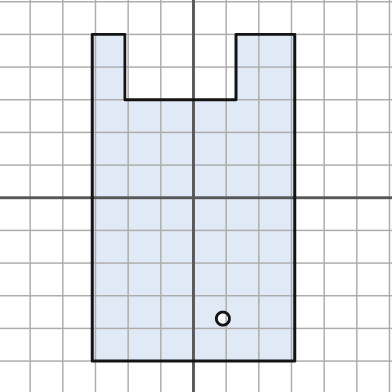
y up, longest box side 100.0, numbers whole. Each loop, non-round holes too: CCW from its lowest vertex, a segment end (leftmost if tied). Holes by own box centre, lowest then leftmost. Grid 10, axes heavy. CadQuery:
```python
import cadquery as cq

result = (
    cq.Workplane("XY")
    .moveTo(-31.0, -50.0)
    .lineTo(31.0, -50.0)
    .lineTo(31.0, 50.0)
    .lineTo(13.0, 50.0)
    .lineTo(13.0, 30.0)
    .lineTo(-21.0, 30.0)
    .lineTo(-21.0, 50.0)
    .lineTo(-31.0, 50.0)
    .close()
    .moveTo(9.0, -37.0)
    .circle(2.0)
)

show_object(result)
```